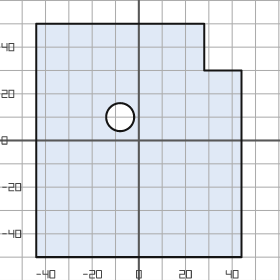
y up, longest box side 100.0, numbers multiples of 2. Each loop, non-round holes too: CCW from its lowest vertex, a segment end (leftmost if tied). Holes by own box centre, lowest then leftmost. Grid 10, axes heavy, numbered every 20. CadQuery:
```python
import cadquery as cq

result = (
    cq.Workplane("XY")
    .moveTo(-44.0, -50.0)
    .lineTo(44.0, -50.0)
    .lineTo(44.0, 30.0)
    .lineTo(28.0, 30.0)
    .lineTo(28.0, 50.0)
    .lineTo(-44.0, 50.0)
    .close()
    .moveTo(-8.0, 10.0)
    .circle(6.0)
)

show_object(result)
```